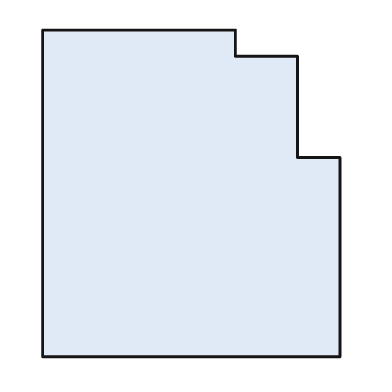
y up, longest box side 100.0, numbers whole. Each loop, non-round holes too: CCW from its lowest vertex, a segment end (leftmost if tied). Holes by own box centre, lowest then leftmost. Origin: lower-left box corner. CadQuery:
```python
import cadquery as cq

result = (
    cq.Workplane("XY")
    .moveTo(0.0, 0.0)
    .lineTo(91.0, 0.0)
    .lineTo(91.0, 61.0)
    .lineTo(78.0, 61.0)
    .lineTo(78.0, 92.0)
    .lineTo(59.0, 92.0)
    .lineTo(59.0, 100.0)
    .lineTo(0.0, 100.0)
    .close()
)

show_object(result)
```